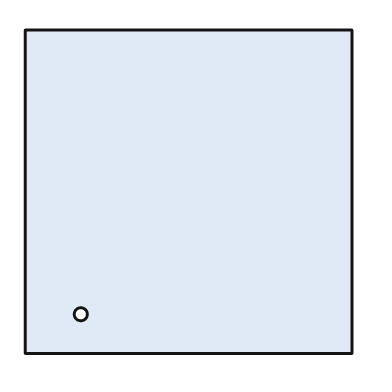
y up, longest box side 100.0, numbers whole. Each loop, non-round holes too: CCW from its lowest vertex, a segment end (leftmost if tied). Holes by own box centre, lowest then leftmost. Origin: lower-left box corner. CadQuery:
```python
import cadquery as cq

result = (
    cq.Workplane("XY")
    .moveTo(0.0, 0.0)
    .lineTo(100.0, 0.0)
    .lineTo(100.0, 99.0)
    .lineTo(0.0, 99.0)
    .close()
    .moveTo(17.0, 12.0)
    .circle(2.0)
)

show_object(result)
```